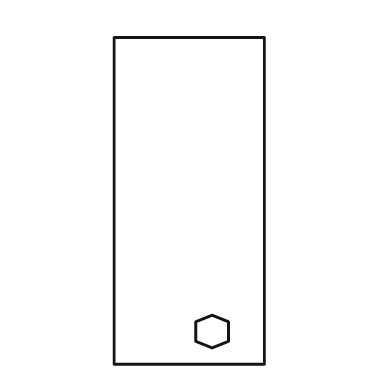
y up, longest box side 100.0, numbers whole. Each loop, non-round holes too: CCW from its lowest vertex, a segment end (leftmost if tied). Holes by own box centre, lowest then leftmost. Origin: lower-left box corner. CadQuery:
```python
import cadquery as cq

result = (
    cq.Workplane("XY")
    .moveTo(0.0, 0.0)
    .lineTo(46.0, 0.0)
    .lineTo(46.0, 100.0)
    .lineTo(0.0, 100.0)
    .close()
    .moveTo(30.0, 5.0)
    .lineTo(35.0, 7.0)
    .lineTo(35.0, 13.0)
    .lineTo(30.0, 15.0)
    .lineTo(25.0, 13.0)
    .lineTo(25.0, 7.0)
    .close()
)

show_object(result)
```